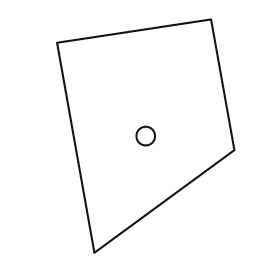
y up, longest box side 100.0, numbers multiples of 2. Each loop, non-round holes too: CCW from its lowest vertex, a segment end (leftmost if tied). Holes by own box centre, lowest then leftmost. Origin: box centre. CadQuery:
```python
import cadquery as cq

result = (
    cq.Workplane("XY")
    .moveTo(-22.0, -50.0)
    .lineTo(38.0, -6.0)
    .lineTo(28.0, 50.0)
    .lineTo(-38.0, 40.0)
    .close()
    .moveTo(0.0, 0.0)
    .circle(4.0)
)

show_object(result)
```